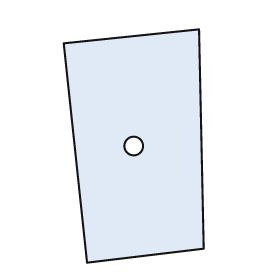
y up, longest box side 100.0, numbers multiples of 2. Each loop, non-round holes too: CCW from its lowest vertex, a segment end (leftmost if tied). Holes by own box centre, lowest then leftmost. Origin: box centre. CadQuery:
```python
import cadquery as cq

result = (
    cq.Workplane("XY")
    .moveTo(-20.0, -50.0)
    .lineTo(30.0, -44.0)
    .lineTo(28.0, 50.0)
    .lineTo(-30.0, 44.0)
    .close()
    .moveTo(0.0, 0.0)
    .circle(4.0)
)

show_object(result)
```